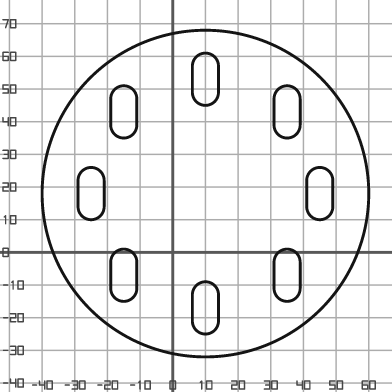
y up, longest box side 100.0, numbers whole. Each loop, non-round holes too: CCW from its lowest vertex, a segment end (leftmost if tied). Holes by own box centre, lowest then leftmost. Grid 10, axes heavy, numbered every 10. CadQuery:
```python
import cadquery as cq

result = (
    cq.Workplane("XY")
    .moveTo(10.0, 18.0)
    .circle(50.0)
    .moveTo(6.0, -21.0)
    .threePointArc((10.0, -25.0), (14.0, -21.0))
    .lineTo(14.0, -13.0)
    .threePointArc((10.0, -9.0), (6.0, -13.0))
    .close()
    .moveTo(-19.0, -11.0)
    .threePointArc((-15.0, -15.0), (-11.0, -11.0))
    .lineTo(-11.0, -3.0)
    .threePointArc((-15.0, 1.0), (-19.0, -3.0))
    .close()
    .moveTo(31.0, -11.0)
    .threePointArc((35.0, -15.0), (39.0, -11.0))
    .lineTo(39.0, -3.0)
    .threePointArc((35.0, 1.0), (31.0, -3.0))
    .close()
    .moveTo(-29.0, 14.0)
    .threePointArc((-25.0, 10.0), (-21.0, 14.0))
    .lineTo(-21.0, 22.0)
    .threePointArc((-25.0, 26.0), (-29.0, 22.0))
    .close()
    .moveTo(41.0, 14.0)
    .threePointArc((45.0, 10.0), (49.0, 14.0))
    .lineTo(49.0, 22.0)
    .threePointArc((45.0, 26.0), (41.0, 22.0))
    .close()
    .moveTo(-19.0, 39.0)
    .threePointArc((-15.0, 35.0), (-11.0, 39.0))
    .lineTo(-11.0, 47.0)
    .threePointArc((-15.0, 51.0), (-19.0, 47.0))
    .close()
    .moveTo(31.0, 39.0)
    .threePointArc((35.0, 35.0), (39.0, 39.0))
    .lineTo(39.0, 47.0)
    .threePointArc((35.0, 51.0), (31.0, 47.0))
    .close()
    .moveTo(6.0, 49.0)
    .threePointArc((10.0, 45.0), (14.0, 49.0))
    .lineTo(14.0, 57.0)
    .threePointArc((10.0, 61.0), (6.0, 57.0))
    .close()
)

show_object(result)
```